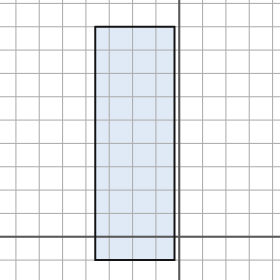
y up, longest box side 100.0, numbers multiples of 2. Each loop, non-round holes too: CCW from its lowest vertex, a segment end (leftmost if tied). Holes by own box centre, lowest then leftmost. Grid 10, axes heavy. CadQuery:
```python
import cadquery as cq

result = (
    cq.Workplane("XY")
    .moveTo(-36.0, -10.0)
    .lineTo(-2.0, -10.0)
    .lineTo(-2.0, 90.0)
    .lineTo(-36.0, 90.0)
    .close()
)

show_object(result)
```